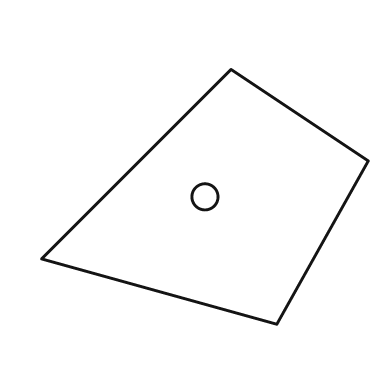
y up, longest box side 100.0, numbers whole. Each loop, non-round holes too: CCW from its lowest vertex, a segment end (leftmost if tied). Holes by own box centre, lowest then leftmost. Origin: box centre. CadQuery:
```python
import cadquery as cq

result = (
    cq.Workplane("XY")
    .moveTo(22.0, -39.0)
    .lineTo(50.0, 11.0)
    .lineTo(8.0, 39.0)
    .lineTo(-50.0, -19.0)
    .close()
    .moveTo(0.0, 0.0)
    .circle(4.0)
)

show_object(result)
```